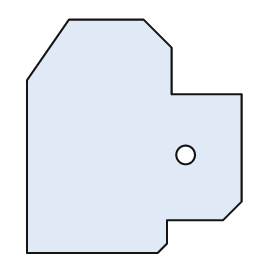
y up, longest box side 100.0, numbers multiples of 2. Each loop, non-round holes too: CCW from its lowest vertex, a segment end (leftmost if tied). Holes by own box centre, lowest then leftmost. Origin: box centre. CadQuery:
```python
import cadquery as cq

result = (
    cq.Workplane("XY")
    .moveTo(-46.0, -50.0)
    .lineTo(10.0, -50.0)
    .lineTo(14.0, -46.0)
    .lineTo(14.0, -36.0)
    .lineTo(38.0, -36.0)
    .lineTo(46.0, -28.0)
    .lineTo(46.0, 18.0)
    .lineTo(16.0, 18.0)
    .lineTo(16.0, 38.0)
    .lineTo(4.0, 50.0)
    .lineTo(-28.0, 50.0)
    .lineTo(-46.0, 24.0)
    .close()
    .moveTo(22.0, -8.0)
    .circle(4.0)
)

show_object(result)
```